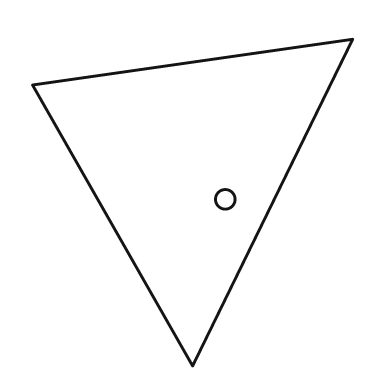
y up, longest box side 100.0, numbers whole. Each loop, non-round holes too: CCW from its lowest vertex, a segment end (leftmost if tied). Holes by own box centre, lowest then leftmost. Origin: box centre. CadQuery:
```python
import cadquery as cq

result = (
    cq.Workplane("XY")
    .moveTo(0.0, -50.0)
    .lineTo(49.0, 50.0)
    .lineTo(-49.0, 36.0)
    .close()
    .moveTo(10.0, 1.0)
    .circle(3.0)
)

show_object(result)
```